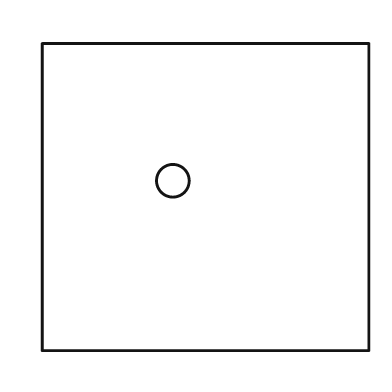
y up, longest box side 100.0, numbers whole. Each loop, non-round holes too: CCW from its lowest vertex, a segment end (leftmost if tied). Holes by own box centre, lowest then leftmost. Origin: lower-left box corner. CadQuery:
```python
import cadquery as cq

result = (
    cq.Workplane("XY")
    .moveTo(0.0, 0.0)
    .lineTo(100.0, 0.0)
    .lineTo(100.0, 94.0)
    .lineTo(0.0, 94.0)
    .close()
    .moveTo(40.0, 52.0)
    .circle(5.0)
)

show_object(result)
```